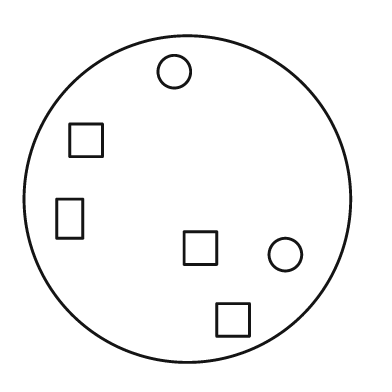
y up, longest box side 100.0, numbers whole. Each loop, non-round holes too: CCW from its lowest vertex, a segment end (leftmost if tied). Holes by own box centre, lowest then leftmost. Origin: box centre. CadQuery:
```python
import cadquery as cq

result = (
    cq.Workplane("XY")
    .moveTo(0.0, 0.0)
    .circle(50.0)
    .moveTo(9.0, -42.0)
    .lineTo(19.0, -42.0)
    .lineTo(19.0, -32.0)
    .lineTo(9.0, -32.0)
    .close()
    .moveTo(30.0, -17.0)
    .circle(5.0)
    .moveTo(-1.0, -20.0)
    .lineTo(9.0, -20.0)
    .lineTo(9.0, -10.0)
    .lineTo(-1.0, -10.0)
    .close()
    .moveTo(-40.0, -12.0)
    .lineTo(-32.0, -12.0)
    .lineTo(-32.0, 0.0)
    .lineTo(-40.0, 0.0)
    .close()
    .moveTo(-36.0, 13.0)
    .lineTo(-26.0, 13.0)
    .lineTo(-26.0, 23.0)
    .lineTo(-36.0, 23.0)
    .close()
    .moveTo(-4.0, 39.0)
    .circle(5.0)
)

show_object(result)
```